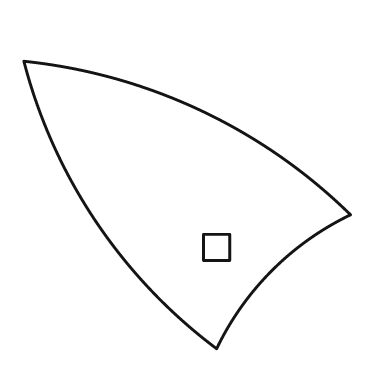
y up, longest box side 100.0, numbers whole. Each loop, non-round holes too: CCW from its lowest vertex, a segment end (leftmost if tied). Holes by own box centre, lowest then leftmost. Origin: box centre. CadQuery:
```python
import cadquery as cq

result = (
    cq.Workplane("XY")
    .moveTo(9.0, -44.0)
    .threePointArc((26.0, -20.0), (50.0, -3.0))
    .threePointArc((4.0, 29.0), (-50.0, 44.0))
    .threePointArc((-28.0, -5.0), (9.0, -44.0))
    .close()
    .moveTo(5.0, -17.0)
    .lineTo(13.0, -17.0)
    .lineTo(13.0, -9.0)
    .lineTo(5.0, -9.0)
    .close()
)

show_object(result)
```